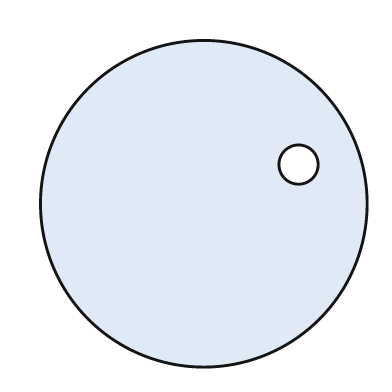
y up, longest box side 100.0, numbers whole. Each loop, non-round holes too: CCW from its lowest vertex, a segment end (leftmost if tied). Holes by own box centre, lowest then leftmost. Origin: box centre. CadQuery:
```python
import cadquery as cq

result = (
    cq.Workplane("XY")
    .moveTo(0.0, 0.0)
    .circle(50.0)
    .moveTo(29.0, 12.0)
    .circle(6.0)
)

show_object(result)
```